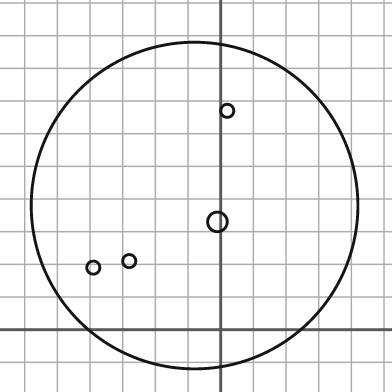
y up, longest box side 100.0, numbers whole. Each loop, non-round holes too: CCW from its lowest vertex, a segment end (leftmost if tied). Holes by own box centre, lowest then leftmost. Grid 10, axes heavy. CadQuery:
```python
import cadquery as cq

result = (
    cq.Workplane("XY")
    .moveTo(-8.0, 38.0)
    .circle(50.0)
    .moveTo(-39.0, 19.0)
    .circle(2.0)
    .moveTo(-28.0, 21.0)
    .circle(2.0)
    .moveTo(-1.0, 33.0)
    .circle(3.0)
    .moveTo(2.0, 67.0)
    .circle(2.0)
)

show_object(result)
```